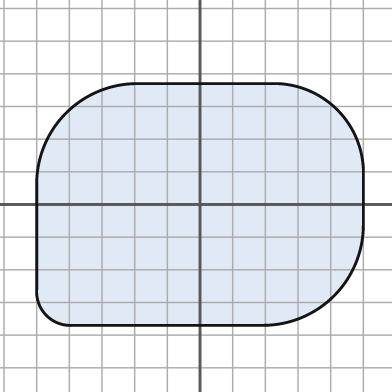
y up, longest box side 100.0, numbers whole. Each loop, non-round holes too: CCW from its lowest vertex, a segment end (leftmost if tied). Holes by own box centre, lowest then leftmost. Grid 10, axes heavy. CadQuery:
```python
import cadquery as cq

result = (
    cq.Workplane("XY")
    .moveTo(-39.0, -37.0)
    .lineTo(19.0, -37.0)
    .threePointArc((41.0, -28.0), (50.0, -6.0))
    .lineTo(50.0, 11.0)
    .threePointArc((42.0, 29.0), (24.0, 37.0))
    .lineTo(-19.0, 37.0)
    .threePointArc((-41.0, 28.0), (-50.0, 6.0))
    .lineTo(-50.0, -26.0)
    .threePointArc((-47.0, -34.0), (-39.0, -37.0))
    .close()
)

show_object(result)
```